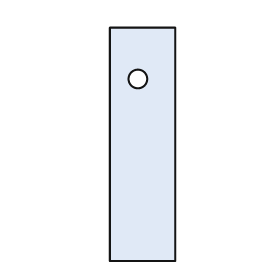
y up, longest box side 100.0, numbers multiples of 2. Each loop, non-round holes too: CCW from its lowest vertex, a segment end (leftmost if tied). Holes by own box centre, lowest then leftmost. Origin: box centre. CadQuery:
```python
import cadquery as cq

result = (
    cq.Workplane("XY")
    .moveTo(-14.0, -50.0)
    .lineTo(14.0, -50.0)
    .lineTo(14.0, 50.0)
    .lineTo(-14.0, 50.0)
    .close()
    .moveTo(-2.0, 28.0)
    .circle(4.0)
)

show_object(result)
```